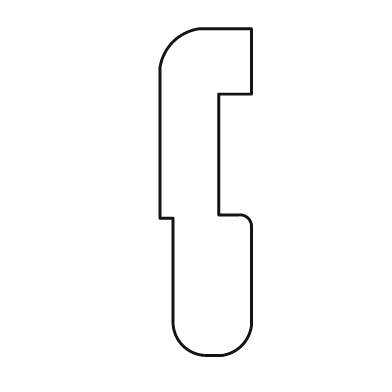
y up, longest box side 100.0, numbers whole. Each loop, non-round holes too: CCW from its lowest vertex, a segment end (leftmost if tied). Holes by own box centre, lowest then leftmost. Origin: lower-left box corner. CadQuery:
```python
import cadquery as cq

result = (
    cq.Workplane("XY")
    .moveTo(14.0, 0.0)
    .lineTo(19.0, 0.0)
    .threePointArc((25.0, 3.0), (28.0, 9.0))
    .lineTo(28.0, 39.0)
    .threePointArc((27.0, 42.0), (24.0, 43.0))
    .lineTo(18.0, 43.0)
    .lineTo(18.0, 80.0)
    .lineTo(28.0, 80.0)
    .lineTo(28.0, 100.0)
    .lineTo(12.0, 100.0)
    .threePointArc((4.0, 96.0), (0.0, 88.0))
    .lineTo(0.0, 42.0)
    .lineTo(4.0, 42.0)
    .lineTo(4.0, 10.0)
    .threePointArc((7.0, 3.0), (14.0, 0.0))
    .close()
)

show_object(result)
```